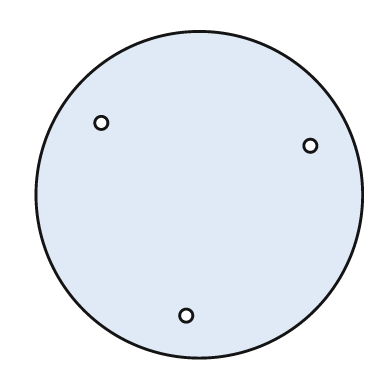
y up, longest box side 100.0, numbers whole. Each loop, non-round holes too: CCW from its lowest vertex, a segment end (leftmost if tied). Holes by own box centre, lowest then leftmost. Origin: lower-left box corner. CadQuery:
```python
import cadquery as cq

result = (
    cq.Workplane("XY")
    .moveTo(50.0, 50.0)
    .circle(50.0)
    .moveTo(46.0, 13.0)
    .circle(2.0)
    .moveTo(84.0, 65.0)
    .circle(2.0)
    .moveTo(20.0, 72.0)
    .circle(2.0)
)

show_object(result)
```